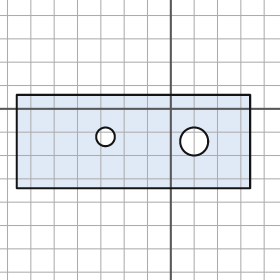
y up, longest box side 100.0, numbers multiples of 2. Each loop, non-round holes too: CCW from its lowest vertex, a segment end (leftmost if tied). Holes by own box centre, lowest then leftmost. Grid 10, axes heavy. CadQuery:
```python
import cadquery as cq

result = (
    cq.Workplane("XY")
    .moveTo(-66.0, -34.0)
    .lineTo(34.0, -34.0)
    .lineTo(34.0, 6.0)
    .lineTo(-66.0, 6.0)
    .close()
    .moveTo(10.0, -14.0)
    .circle(6.0)
    .moveTo(-28.0, -12.0)
    .circle(4.0)
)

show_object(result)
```